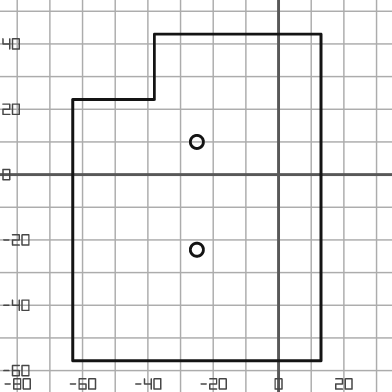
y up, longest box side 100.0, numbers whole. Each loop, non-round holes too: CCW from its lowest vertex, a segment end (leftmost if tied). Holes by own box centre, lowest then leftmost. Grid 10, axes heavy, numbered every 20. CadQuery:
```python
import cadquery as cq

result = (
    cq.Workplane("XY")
    .moveTo(-63.0, -57.0)
    .lineTo(13.0, -57.0)
    .lineTo(13.0, 43.0)
    .lineTo(-38.0, 43.0)
    .lineTo(-38.0, 23.0)
    .lineTo(-63.0, 23.0)
    .close()
    .moveTo(-25.0, -23.0)
    .circle(2.0)
    .moveTo(-25.0, 10.0)
    .circle(2.0)
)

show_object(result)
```